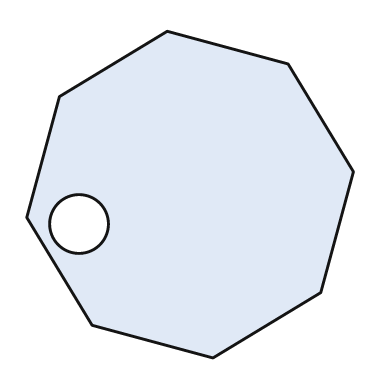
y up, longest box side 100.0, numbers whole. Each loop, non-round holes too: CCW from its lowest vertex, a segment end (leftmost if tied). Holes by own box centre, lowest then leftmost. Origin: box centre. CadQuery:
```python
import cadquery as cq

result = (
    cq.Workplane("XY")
    .moveTo(7.0, -50.0)
    .lineTo(40.0, -30.0)
    .lineTo(50.0, 7.0)
    .lineTo(30.0, 40.0)
    .lineTo(-7.0, 50.0)
    .lineTo(-40.0, 30.0)
    .lineTo(-50.0, -7.0)
    .lineTo(-30.0, -40.0)
    .close()
    .moveTo(-34.0, -9.0)
    .circle(9.0)
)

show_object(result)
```